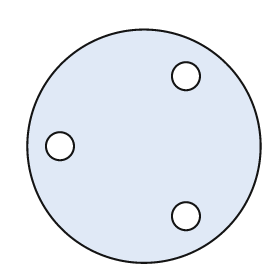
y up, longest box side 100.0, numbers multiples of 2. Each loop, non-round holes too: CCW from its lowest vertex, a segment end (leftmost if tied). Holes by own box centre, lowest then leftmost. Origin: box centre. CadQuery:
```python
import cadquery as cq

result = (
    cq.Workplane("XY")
    .moveTo(0.0, 0.0)
    .circle(50.0)
    .moveTo(18.0, -30.0)
    .circle(6.0)
    .moveTo(-36.0, 0.0)
    .circle(6.0)
    .moveTo(18.0, 30.0)
    .circle(6.0)
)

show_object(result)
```